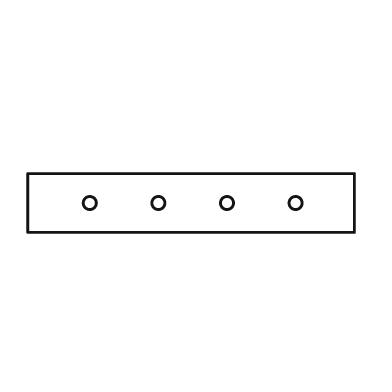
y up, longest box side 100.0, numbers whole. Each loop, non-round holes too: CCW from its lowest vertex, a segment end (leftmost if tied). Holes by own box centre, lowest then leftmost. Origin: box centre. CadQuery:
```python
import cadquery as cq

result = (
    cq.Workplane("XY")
    .moveTo(-50.0, -9.0)
    .lineTo(50.0, -9.0)
    .lineTo(50.0, 9.0)
    .lineTo(-50.0, 9.0)
    .close()
    .moveTo(-31.0, 0.0)
    .circle(2.0)
    .moveTo(-10.0, 0.0)
    .circle(2.0)
    .moveTo(11.0, 0.0)
    .circle(2.0)
    .moveTo(32.0, 0.0)
    .circle(2.0)
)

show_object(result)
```